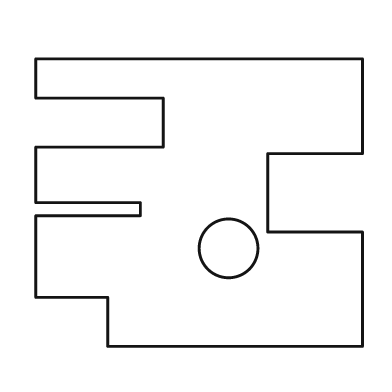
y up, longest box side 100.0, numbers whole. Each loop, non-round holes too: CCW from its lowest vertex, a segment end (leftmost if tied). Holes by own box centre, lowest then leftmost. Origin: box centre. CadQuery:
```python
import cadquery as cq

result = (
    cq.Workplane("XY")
    .moveTo(-28.0, -44.0)
    .lineTo(50.0, -44.0)
    .lineTo(50.0, -9.0)
    .lineTo(21.0, -9.0)
    .lineTo(21.0, 15.0)
    .lineTo(50.0, 15.0)
    .lineTo(50.0, 44.0)
    .lineTo(-50.0, 44.0)
    .lineTo(-50.0, 32.0)
    .lineTo(-11.0, 32.0)
    .lineTo(-11.0, 17.0)
    .lineTo(-50.0, 17.0)
    .lineTo(-50.0, 0.0)
    .lineTo(-18.0, 0.0)
    .lineTo(-18.0, -4.0)
    .lineTo(-50.0, -4.0)
    .lineTo(-50.0, -29.0)
    .lineTo(-28.0, -29.0)
    .close()
    .moveTo(9.0, -14.0)
    .circle(9.0)
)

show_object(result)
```